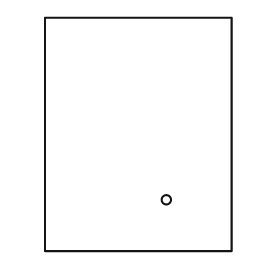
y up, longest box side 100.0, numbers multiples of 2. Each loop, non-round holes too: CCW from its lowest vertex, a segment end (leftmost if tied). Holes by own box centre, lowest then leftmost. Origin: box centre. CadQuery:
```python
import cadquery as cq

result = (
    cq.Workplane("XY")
    .moveTo(-40.0, -50.0)
    .lineTo(40.0, -50.0)
    .lineTo(40.0, 50.0)
    .lineTo(-40.0, 50.0)
    .close()
    .moveTo(12.0, -28.0)
    .circle(2.0)
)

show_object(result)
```